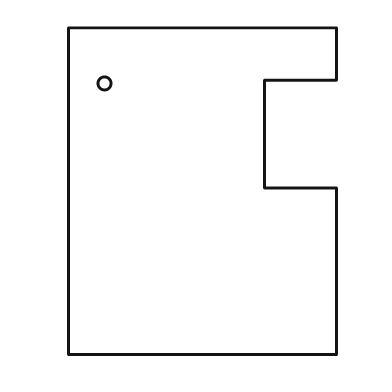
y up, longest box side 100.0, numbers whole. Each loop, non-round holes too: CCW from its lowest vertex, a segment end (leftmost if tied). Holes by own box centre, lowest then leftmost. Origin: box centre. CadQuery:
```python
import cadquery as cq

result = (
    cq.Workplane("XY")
    .moveTo(-41.0, -50.0)
    .lineTo(41.0, -50.0)
    .lineTo(41.0, 1.0)
    .lineTo(19.0, 1.0)
    .lineTo(19.0, 34.0)
    .lineTo(41.0, 34.0)
    .lineTo(41.0, 50.0)
    .lineTo(-41.0, 50.0)
    .close()
    .moveTo(-30.0, 33.0)
    .circle(2.0)
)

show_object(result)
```